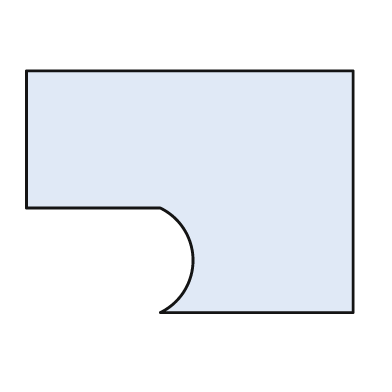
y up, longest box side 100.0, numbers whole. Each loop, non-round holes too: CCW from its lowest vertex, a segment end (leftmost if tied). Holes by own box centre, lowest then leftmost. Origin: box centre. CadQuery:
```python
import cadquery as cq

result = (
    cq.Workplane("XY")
    .moveTo(-9.0, -37.0)
    .lineTo(50.0, -37.0)
    .lineTo(50.0, 37.0)
    .lineTo(-50.0, 37.0)
    .lineTo(-50.0, -5.0)
    .lineTo(-9.0, -5.0)
    .threePointArc((1.0, -21.0), (-9.0, -37.0))
    .close()
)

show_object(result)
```